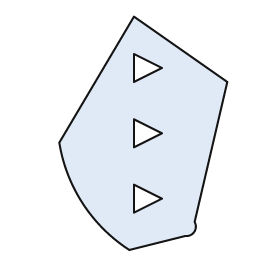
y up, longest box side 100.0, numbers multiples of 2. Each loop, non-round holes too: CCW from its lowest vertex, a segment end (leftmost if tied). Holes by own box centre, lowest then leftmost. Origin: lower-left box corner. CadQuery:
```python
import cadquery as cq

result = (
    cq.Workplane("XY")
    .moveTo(30.0, 0.0)
    .lineTo(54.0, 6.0)
    .threePointArc((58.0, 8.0), (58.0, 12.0))
    .lineTo(72.0, 72.0)
    .lineTo(32.0, 100.0)
    .lineTo(0.0, 46.0)
    .threePointArc((10.0, 20.0), (30.0, 0.0))
    .close()
    .moveTo(32.0, 16.0)
    .lineTo(44.0, 22.0)
    .lineTo(32.0, 28.0)
    .close()
    .moveTo(32.0, 44.0)
    .lineTo(44.0, 50.0)
    .lineTo(32.0, 56.0)
    .close()
    .moveTo(32.0, 72.0)
    .lineTo(44.0, 78.0)
    .lineTo(32.0, 84.0)
    .close()
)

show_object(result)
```